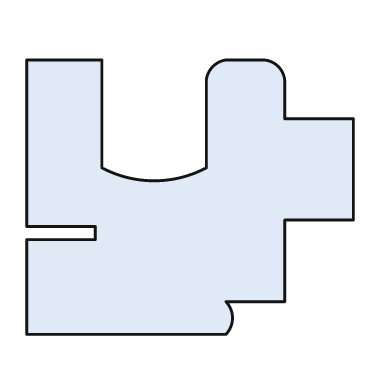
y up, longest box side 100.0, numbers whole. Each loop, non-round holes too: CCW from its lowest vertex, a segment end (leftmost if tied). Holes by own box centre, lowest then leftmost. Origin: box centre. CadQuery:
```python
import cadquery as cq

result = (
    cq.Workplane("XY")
    .moveTo(-50.0, -42.0)
    .lineTo(11.0, -42.0)
    .threePointArc((13.0, -37.0), (11.0, -32.0))
    .lineTo(29.0, -32.0)
    .lineTo(29.0, -7.0)
    .lineTo(50.0, -7.0)
    .lineTo(50.0, 24.0)
    .lineTo(29.0, 24.0)
    .lineTo(29.0, 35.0)
    .threePointArc((27.0, 40.0), (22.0, 42.0))
    .lineTo(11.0, 42.0)
    .threePointArc((7.0, 40.0), (5.0, 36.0))
    .lineTo(5.0, 9.0)
    .threePointArc((-11.0, 5.0), (-27.0, 9.0))
    .lineTo(-27.0, 42.0)
    .lineTo(-50.0, 42.0)
    .lineTo(-50.0, -9.0)
    .lineTo(-29.0, -9.0)
    .lineTo(-29.0, -13.0)
    .lineTo(-50.0, -13.0)
    .close()
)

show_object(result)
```